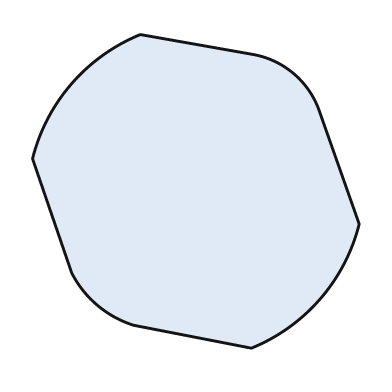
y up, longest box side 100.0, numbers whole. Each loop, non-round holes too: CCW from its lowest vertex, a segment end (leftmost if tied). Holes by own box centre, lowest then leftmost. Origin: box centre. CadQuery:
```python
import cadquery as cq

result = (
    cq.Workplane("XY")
    .moveTo(17.0, -48.0)
    .threePointArc((38.0, -33.0), (50.0, -10.0))
    .lineTo(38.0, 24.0)
    .threePointArc((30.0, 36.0), (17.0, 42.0))
    .lineTo(-17.0, 48.0)
    .threePointArc((-38.0, 33.0), (-50.0, 10.0))
    .lineTo(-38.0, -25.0)
    .threePointArc((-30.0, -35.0), (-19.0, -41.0))
    .close()
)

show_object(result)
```